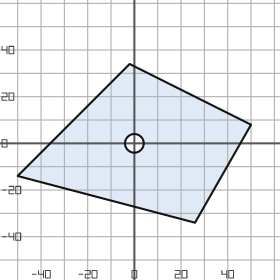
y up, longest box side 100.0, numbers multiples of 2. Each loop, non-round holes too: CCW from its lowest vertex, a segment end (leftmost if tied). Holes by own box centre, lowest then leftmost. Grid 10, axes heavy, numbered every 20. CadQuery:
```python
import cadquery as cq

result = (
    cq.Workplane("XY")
    .moveTo(26.0, -34.0)
    .lineTo(50.0, 8.0)
    .lineTo(-2.0, 34.0)
    .lineTo(-50.0, -14.0)
    .close()
    .moveTo(0.0, 0.0)
    .circle(4.0)
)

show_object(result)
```